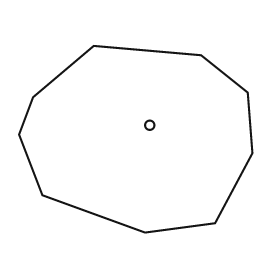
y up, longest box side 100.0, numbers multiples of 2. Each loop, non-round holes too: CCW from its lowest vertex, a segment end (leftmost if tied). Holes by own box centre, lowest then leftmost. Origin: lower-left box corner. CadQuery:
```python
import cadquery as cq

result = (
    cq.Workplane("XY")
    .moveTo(54.0, 0.0)
    .lineTo(84.0, 4.0)
    .lineTo(100.0, 34.0)
    .lineTo(98.0, 60.0)
    .lineTo(78.0, 76.0)
    .lineTo(32.0, 80.0)
    .lineTo(6.0, 58.0)
    .lineTo(0.0, 42.0)
    .lineTo(10.0, 16.0)
    .close()
    .moveTo(56.0, 46.0)
    .circle(2.0)
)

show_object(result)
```